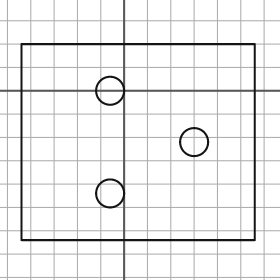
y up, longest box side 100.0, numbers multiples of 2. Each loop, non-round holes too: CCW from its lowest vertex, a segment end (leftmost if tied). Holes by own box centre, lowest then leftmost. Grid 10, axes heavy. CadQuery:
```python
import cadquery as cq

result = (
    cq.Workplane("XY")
    .moveTo(-44.0, -64.0)
    .lineTo(56.0, -64.0)
    .lineTo(56.0, 20.0)
    .lineTo(-44.0, 20.0)
    .close()
    .moveTo(-6.0, -44.0)
    .circle(6.0)
    .moveTo(30.0, -22.0)
    .circle(6.0)
    .moveTo(-6.0, 0.0)
    .circle(6.0)
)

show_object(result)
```